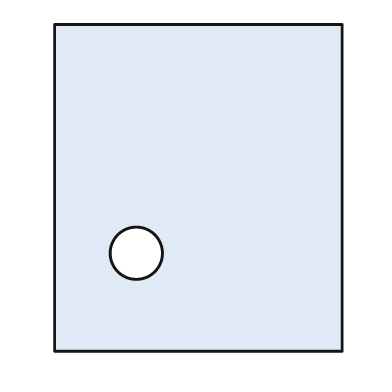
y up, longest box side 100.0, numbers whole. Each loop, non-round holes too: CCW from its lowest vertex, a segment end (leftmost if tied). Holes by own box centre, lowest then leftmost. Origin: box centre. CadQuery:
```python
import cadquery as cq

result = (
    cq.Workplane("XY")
    .moveTo(-44.0, -50.0)
    .lineTo(44.0, -50.0)
    .lineTo(44.0, 50.0)
    .lineTo(-44.0, 50.0)
    .close()
    .moveTo(-19.0, -20.0)
    .circle(8.0)
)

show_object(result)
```